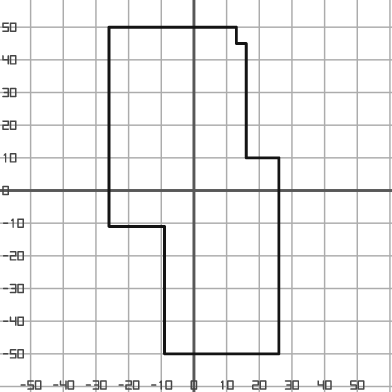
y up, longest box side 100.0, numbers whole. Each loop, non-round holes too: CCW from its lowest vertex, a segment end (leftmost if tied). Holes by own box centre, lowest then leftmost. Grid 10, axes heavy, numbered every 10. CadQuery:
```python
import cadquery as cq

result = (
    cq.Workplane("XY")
    .moveTo(-9.0, -50.0)
    .lineTo(26.0, -50.0)
    .lineTo(26.0, 10.0)
    .lineTo(16.0, 10.0)
    .lineTo(16.0, 45.0)
    .lineTo(13.0, 45.0)
    .lineTo(13.0, 50.0)
    .lineTo(-26.0, 50.0)
    .lineTo(-26.0, -11.0)
    .lineTo(-9.0, -11.0)
    .close()
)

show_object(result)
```